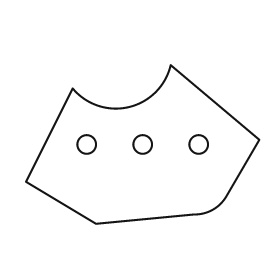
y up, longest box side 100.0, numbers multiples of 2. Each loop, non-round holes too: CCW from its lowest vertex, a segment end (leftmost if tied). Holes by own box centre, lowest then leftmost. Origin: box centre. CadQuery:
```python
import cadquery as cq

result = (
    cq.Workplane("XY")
    .moveTo(-20.0, -34.0)
    .lineTo(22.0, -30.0)
    .threePointArc((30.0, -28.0), (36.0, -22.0))
    .lineTo(50.0, 2.0)
    .lineTo(12.0, 34.0)
    .threePointArc((-6.0, 16.0), (-30.0, 24.0))
    .lineTo(-50.0, -16.0)
    .close()
    .moveTo(-24.0, 0.0)
    .circle(4.0)
    .moveTo(0.0, 0.0)
    .circle(4.0)
    .moveTo(24.0, 0.0)
    .circle(4.0)
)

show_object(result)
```